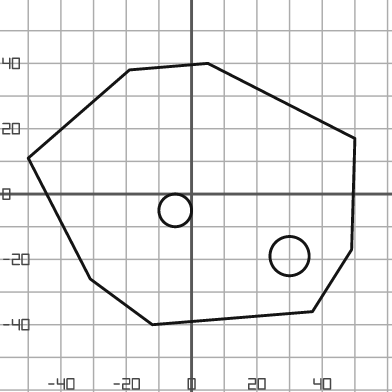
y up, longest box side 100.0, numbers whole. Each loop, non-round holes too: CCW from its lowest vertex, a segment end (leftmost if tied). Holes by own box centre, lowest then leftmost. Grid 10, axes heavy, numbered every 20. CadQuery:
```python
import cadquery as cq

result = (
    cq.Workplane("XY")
    .moveTo(-12.0, -40.0)
    .lineTo(37.0, -36.0)
    .lineTo(49.0, -17.0)
    .lineTo(50.0, 17.0)
    .lineTo(5.0, 40.0)
    .lineTo(-19.0, 38.0)
    .lineTo(-50.0, 11.0)
    .lineTo(-31.0, -26.0)
    .close()
    .moveTo(30.0, -19.0)
    .circle(6.0)
    .moveTo(-5.0, -5.0)
    .circle(5.0)
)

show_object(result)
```